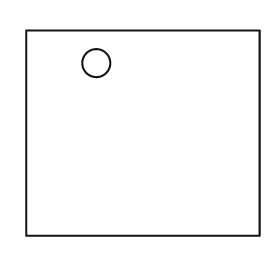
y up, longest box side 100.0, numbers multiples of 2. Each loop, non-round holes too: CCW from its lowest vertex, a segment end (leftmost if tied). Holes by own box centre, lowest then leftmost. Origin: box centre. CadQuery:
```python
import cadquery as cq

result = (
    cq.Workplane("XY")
    .moveTo(-50.0, -44.0)
    .lineTo(50.0, -44.0)
    .lineTo(50.0, 44.0)
    .lineTo(-50.0, 44.0)
    .close()
    .moveTo(-20.0, 30.0)
    .circle(6.0)
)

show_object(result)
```